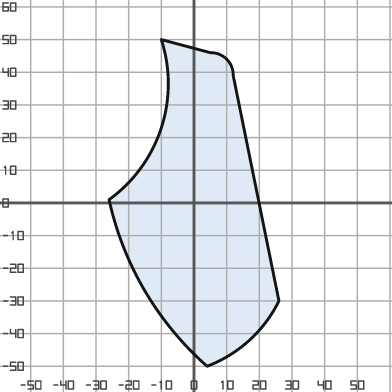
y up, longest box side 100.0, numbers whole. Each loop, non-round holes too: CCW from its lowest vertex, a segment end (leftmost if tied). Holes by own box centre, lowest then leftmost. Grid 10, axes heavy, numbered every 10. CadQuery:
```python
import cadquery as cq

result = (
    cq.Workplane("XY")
    .moveTo(4.0, -50.0)
    .threePointArc((17.0, -42.0), (26.0, -30.0))
    .lineTo(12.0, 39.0)
    .threePointArc((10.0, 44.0), (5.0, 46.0))
    .lineTo(-10.0, 50.0)
    .threePointArc((-10.0, 23.0), (-26.0, 1.0))
    .threePointArc((-15.0, -27.0), (4.0, -50.0))
    .close()
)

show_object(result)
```